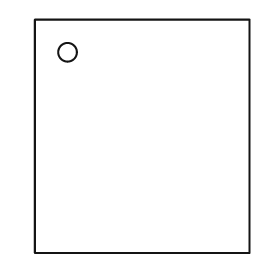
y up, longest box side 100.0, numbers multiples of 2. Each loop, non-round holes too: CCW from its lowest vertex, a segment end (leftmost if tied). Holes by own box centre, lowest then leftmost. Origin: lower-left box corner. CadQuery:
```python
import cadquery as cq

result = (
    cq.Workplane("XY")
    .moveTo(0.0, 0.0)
    .lineTo(92.0, 0.0)
    .lineTo(92.0, 100.0)
    .lineTo(0.0, 100.0)
    .close()
    .moveTo(14.0, 86.0)
    .circle(4.0)
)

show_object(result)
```